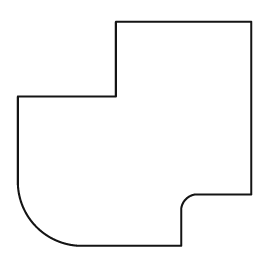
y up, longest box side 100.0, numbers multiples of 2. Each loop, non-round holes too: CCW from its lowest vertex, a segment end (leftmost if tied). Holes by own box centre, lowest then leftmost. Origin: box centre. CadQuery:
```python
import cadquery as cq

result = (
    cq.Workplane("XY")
    .moveTo(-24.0, -48.0)
    .lineTo(20.0, -48.0)
    .lineTo(20.0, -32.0)
    .threePointArc((22.0, -28.0), (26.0, -26.0))
    .lineTo(50.0, -26.0)
    .lineTo(50.0, 48.0)
    .lineTo(-8.0, 48.0)
    .lineTo(-8.0, 16.0)
    .lineTo(-50.0, 16.0)
    .lineTo(-50.0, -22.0)
    .threePointArc((-42.0, -40.0), (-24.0, -48.0))
    .close()
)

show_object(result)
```